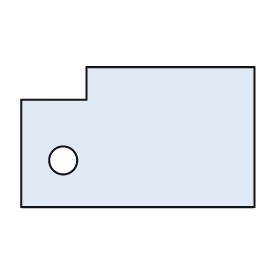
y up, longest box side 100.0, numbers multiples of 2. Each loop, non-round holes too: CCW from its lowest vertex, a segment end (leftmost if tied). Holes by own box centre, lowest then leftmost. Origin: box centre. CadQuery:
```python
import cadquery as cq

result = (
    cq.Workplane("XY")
    .moveTo(-50.0, -30.0)
    .lineTo(50.0, -30.0)
    .lineTo(50.0, 30.0)
    .lineTo(-22.0, 30.0)
    .lineTo(-22.0, 16.0)
    .lineTo(-50.0, 16.0)
    .close()
    .moveTo(-32.0, -10.0)
    .circle(6.0)
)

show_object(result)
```